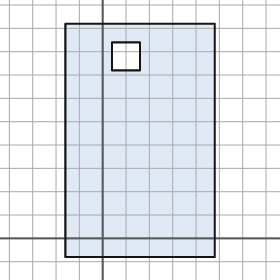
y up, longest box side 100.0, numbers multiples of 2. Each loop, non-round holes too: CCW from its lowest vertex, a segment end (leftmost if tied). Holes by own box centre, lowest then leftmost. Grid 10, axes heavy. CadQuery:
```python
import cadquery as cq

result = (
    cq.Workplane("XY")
    .moveTo(-16.0, -8.0)
    .lineTo(48.0, -8.0)
    .lineTo(48.0, 92.0)
    .lineTo(-16.0, 92.0)
    .close()
    .moveTo(4.0, 72.0)
    .lineTo(16.0, 72.0)
    .lineTo(16.0, 84.0)
    .lineTo(4.0, 84.0)
    .close()
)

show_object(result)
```